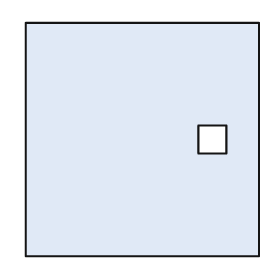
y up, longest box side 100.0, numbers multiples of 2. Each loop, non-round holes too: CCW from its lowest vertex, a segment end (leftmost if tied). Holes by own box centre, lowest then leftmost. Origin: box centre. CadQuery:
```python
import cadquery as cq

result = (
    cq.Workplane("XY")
    .moveTo(-50.0, -50.0)
    .lineTo(50.0, -50.0)
    .lineTo(50.0, 50.0)
    .lineTo(-50.0, 50.0)
    .close()
    .moveTo(24.0, -6.0)
    .lineTo(36.0, -6.0)
    .lineTo(36.0, 6.0)
    .lineTo(24.0, 6.0)
    .close()
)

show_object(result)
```